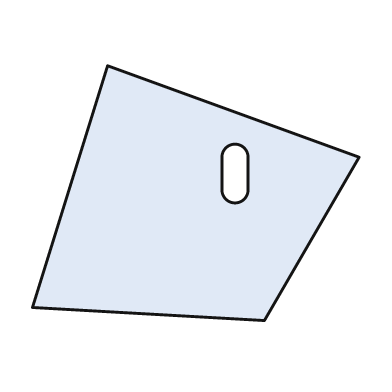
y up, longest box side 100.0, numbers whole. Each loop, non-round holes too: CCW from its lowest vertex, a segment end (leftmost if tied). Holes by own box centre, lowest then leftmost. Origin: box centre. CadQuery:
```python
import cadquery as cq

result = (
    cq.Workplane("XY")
    .moveTo(21.0, -39.0)
    .lineTo(50.0, 11.0)
    .lineTo(-27.0, 39.0)
    .lineTo(-50.0, -35.0)
    .close()
    .moveTo(8.0, 1.0)
    .threePointArc((12.0, -3.0), (16.0, 1.0))
    .lineTo(16.0, 11.0)
    .threePointArc((12.0, 15.0), (8.0, 11.0))
    .close()
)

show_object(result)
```